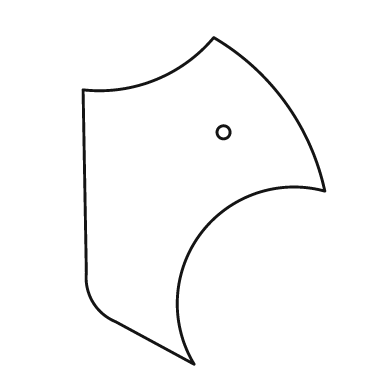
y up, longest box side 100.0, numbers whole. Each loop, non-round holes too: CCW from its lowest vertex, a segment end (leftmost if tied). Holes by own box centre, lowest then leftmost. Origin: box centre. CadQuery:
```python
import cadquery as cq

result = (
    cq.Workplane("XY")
    .moveTo(-3.0, -50.0)
    .threePointArc((-1.0, -10.0), (37.0, 3.0))
    .threePointArc((25.0, 30.0), (3.0, 50.0))
    .threePointArc((-15.0, 37.0), (-37.0, 34.0))
    .lineTo(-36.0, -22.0)
    .threePointArc((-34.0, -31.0), (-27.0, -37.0))
    .close()
    .moveTo(6.0, 21.0)
    .circle(2.0)
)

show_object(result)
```